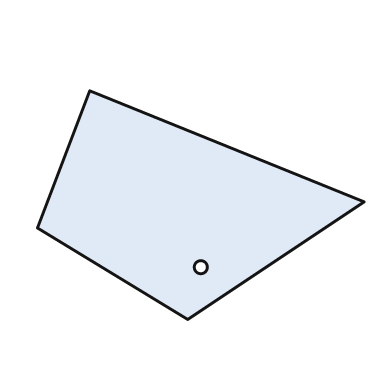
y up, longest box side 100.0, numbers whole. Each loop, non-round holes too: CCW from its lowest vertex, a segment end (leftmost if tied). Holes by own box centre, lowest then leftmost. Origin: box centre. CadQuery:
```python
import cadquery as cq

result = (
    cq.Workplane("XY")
    .moveTo(-4.0, -35.0)
    .lineTo(50.0, 1.0)
    .lineTo(-34.0, 35.0)
    .lineTo(-50.0, -7.0)
    .close()
    .moveTo(0.0, -19.0)
    .circle(2.0)
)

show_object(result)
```